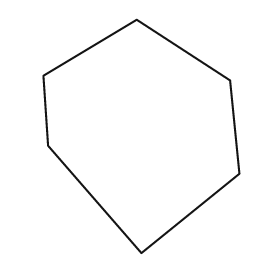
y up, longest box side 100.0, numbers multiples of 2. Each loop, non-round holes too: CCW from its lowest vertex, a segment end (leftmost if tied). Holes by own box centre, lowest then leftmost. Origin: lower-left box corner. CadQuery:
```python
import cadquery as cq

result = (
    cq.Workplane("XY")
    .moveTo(42.0, 0.0)
    .lineTo(84.0, 34.0)
    .lineTo(80.0, 74.0)
    .lineTo(40.0, 100.0)
    .lineTo(0.0, 76.0)
    .lineTo(2.0, 46.0)
    .close()
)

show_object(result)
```